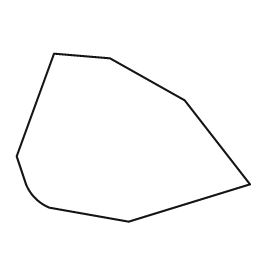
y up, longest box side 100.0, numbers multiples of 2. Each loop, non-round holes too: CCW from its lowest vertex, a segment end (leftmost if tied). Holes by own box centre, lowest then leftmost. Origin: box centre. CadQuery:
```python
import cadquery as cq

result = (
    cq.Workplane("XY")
    .moveTo(-2.0, -36.0)
    .lineTo(50.0, -20.0)
    .lineTo(22.0, 16.0)
    .lineTo(-10.0, 34.0)
    .lineTo(-34.0, 36.0)
    .lineTo(-50.0, -8.0)
    .lineTo(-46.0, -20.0)
    .threePointArc((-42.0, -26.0), (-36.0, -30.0))
    .close()
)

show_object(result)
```